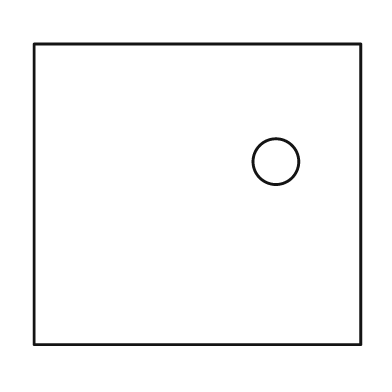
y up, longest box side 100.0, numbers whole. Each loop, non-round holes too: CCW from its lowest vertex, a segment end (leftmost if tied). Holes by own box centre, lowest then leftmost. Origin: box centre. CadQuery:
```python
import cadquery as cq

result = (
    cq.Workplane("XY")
    .moveTo(-50.0, -46.0)
    .lineTo(50.0, -46.0)
    .lineTo(50.0, 46.0)
    .lineTo(-50.0, 46.0)
    .close()
    .moveTo(24.0, 10.0)
    .circle(7.0)
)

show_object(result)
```